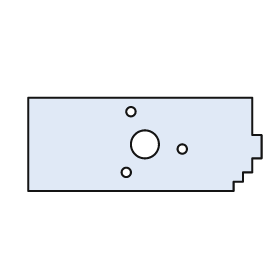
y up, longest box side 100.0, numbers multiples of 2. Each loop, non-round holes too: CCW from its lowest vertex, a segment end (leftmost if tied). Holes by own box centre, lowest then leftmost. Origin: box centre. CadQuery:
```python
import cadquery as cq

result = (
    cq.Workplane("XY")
    .moveTo(-50.0, -20.0)
    .lineTo(38.0, -20.0)
    .lineTo(38.0, -16.0)
    .lineTo(42.0, -16.0)
    .lineTo(42.0, -12.0)
    .lineTo(46.0, -12.0)
    .lineTo(46.0, -6.0)
    .lineTo(50.0, -6.0)
    .lineTo(50.0, 4.0)
    .lineTo(46.0, 4.0)
    .lineTo(46.0, 20.0)
    .lineTo(-50.0, 20.0)
    .close()
    .moveTo(-8.0, -12.0)
    .circle(2.0)
    .moveTo(16.0, -2.0)
    .circle(2.0)
    .moveTo(0.0, 0.0)
    .circle(6.0)
    .moveTo(-6.0, 14.0)
    .circle(2.0)
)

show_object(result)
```